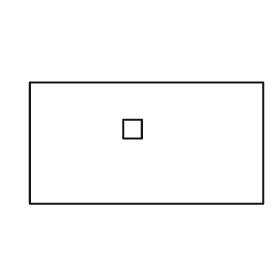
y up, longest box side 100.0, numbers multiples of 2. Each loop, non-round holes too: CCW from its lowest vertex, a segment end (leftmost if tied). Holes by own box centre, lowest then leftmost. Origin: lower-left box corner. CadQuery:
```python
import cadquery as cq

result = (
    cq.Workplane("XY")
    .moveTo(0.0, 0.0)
    .lineTo(100.0, 0.0)
    .lineTo(100.0, 52.0)
    .lineTo(0.0, 52.0)
    .close()
    .moveTo(40.0, 28.0)
    .lineTo(48.0, 28.0)
    .lineTo(48.0, 36.0)
    .lineTo(40.0, 36.0)
    .close()
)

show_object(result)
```